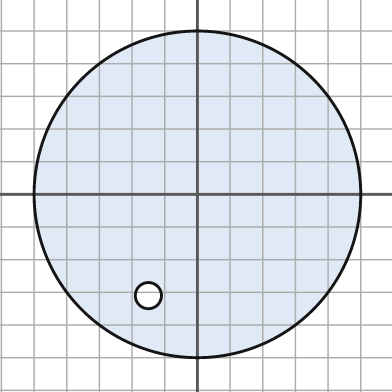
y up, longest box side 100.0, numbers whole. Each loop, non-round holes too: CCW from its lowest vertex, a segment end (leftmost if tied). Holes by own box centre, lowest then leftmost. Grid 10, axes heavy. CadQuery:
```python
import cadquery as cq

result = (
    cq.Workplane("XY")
    .moveTo(0.0, 0.0)
    .circle(50.0)
    .moveTo(-15.0, -31.0)
    .circle(4.0)
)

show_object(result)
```